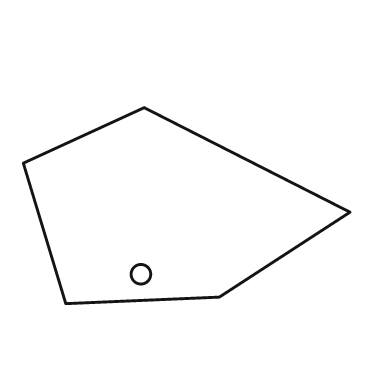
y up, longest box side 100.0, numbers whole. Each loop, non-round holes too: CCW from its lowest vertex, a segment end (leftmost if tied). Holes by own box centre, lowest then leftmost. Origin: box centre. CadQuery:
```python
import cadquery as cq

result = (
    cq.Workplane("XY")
    .moveTo(-37.0, -30.0)
    .lineTo(10.0, -28.0)
    .lineTo(50.0, -2.0)
    .lineTo(-13.0, 30.0)
    .lineTo(-50.0, 13.0)
    .close()
    .moveTo(-14.0, -21.0)
    .circle(3.0)
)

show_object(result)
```